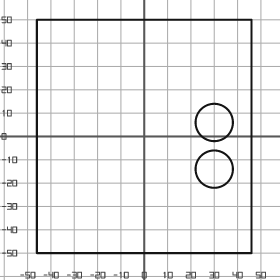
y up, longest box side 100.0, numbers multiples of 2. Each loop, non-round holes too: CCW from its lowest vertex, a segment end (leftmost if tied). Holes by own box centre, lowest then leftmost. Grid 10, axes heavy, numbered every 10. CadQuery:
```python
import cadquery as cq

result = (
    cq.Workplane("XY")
    .moveTo(-46.0, -50.0)
    .lineTo(46.0, -50.0)
    .lineTo(46.0, 50.0)
    .lineTo(-46.0, 50.0)
    .close()
    .moveTo(30.0, -14.0)
    .circle(8.0)
    .moveTo(30.0, 6.0)
    .circle(8.0)
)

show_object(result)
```